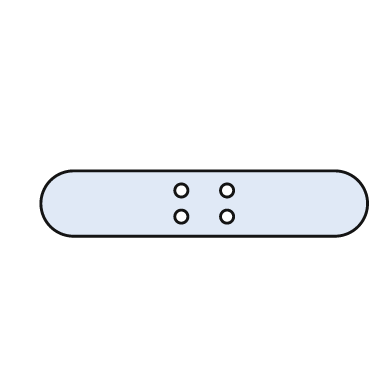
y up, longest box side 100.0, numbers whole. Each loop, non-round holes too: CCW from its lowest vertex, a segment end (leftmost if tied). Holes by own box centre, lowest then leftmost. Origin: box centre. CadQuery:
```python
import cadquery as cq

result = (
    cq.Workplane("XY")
    .moveTo(-40.0, -10.0)
    .lineTo(40.0, -10.0)
    .threePointArc((50.0, 0.0), (40.0, 10.0))
    .lineTo(-40.0, 10.0)
    .threePointArc((-50.0, 0.0), (-40.0, -10.0))
    .close()
    .moveTo(-7.0, -4.0)
    .circle(2.0)
    .moveTo(7.0, -4.0)
    .circle(2.0)
    .moveTo(-7.0, 4.0)
    .circle(2.0)
    .moveTo(7.0, 4.0)
    .circle(2.0)
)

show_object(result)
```